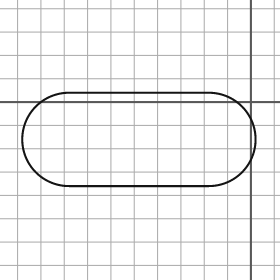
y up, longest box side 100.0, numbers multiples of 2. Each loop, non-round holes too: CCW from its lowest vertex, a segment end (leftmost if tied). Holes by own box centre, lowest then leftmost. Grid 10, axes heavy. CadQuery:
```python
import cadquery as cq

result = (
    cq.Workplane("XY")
    .moveTo(-78.0, -36.0)
    .lineTo(-18.0, -36.0)
    .threePointArc((2.0, -16.0), (-18.0, 4.0))
    .lineTo(-78.0, 4.0)
    .threePointArc((-98.0, -16.0), (-78.0, -36.0))
    .close()
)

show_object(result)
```